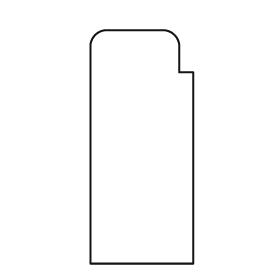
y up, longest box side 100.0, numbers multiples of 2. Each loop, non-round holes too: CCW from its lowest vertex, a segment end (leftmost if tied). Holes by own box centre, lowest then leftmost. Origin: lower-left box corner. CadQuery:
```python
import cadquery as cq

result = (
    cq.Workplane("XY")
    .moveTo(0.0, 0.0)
    .lineTo(44.0, 0.0)
    .lineTo(44.0, 82.0)
    .lineTo(38.0, 82.0)
    .lineTo(38.0, 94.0)
    .threePointArc((36.0, 98.0), (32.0, 100.0))
    .lineTo(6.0, 100.0)
    .threePointArc((2.0, 98.0), (0.0, 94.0))
    .close()
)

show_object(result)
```